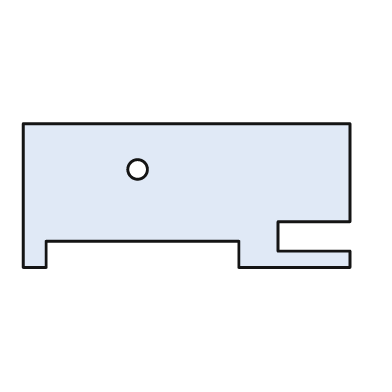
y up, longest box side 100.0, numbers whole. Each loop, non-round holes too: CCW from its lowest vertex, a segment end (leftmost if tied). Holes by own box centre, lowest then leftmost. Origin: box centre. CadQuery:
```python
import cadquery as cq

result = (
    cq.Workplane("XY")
    .moveTo(-50.0, -22.0)
    .lineTo(-43.0, -22.0)
    .lineTo(-43.0, -14.0)
    .lineTo(16.0, -14.0)
    .lineTo(16.0, -22.0)
    .lineTo(50.0, -22.0)
    .lineTo(50.0, -17.0)
    .lineTo(28.0, -17.0)
    .lineTo(28.0, -8.0)
    .lineTo(50.0, -8.0)
    .lineTo(50.0, 22.0)
    .lineTo(-50.0, 22.0)
    .close()
    .moveTo(-15.0, 8.0)
    .circle(3.0)
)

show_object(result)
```